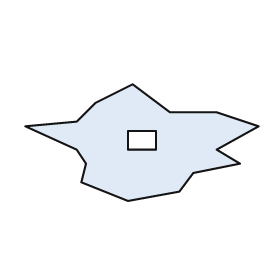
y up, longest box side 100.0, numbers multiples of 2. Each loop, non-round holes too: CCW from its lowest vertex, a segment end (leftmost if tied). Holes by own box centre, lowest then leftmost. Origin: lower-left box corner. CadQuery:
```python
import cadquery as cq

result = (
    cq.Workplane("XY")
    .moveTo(44.0, 0.0)
    .lineTo(66.0, 4.0)
    .lineTo(72.0, 12.0)
    .lineTo(92.0, 16.0)
    .lineTo(82.0, 22.0)
    .lineTo(100.0, 32.0)
    .lineTo(82.0, 38.0)
    .lineTo(62.0, 38.0)
    .lineTo(46.0, 50.0)
    .lineTo(30.0, 42.0)
    .lineTo(22.0, 34.0)
    .lineTo(0.0, 32.0)
    .lineTo(22.0, 22.0)
    .lineTo(26.0, 16.0)
    .lineTo(24.0, 8.0)
    .close()
    .moveTo(44.0, 22.0)
    .lineTo(56.0, 22.0)
    .lineTo(56.0, 30.0)
    .lineTo(44.0, 30.0)
    .close()
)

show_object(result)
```